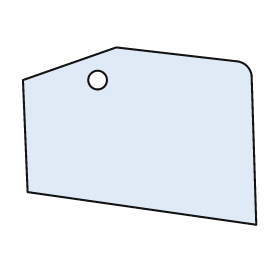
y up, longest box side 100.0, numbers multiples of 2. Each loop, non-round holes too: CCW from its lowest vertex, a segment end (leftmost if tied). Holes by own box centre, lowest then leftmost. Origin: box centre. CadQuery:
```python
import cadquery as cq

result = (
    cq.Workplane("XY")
    .moveTo(50.0, -38.0)
    .lineTo(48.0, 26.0)
    .threePointArc((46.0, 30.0), (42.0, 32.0))
    .lineTo(-10.0, 38.0)
    .lineTo(-50.0, 24.0)
    .lineTo(-48.0, -24.0)
    .close()
    .moveTo(-18.0, 24.0)
    .circle(4.0)
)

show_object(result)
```